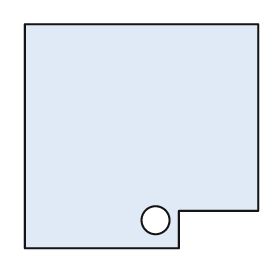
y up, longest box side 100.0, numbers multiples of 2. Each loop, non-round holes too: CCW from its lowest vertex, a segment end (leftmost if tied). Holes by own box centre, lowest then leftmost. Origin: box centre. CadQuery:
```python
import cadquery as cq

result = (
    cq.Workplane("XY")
    .moveTo(-50.0, -48.0)
    .lineTo(16.0, -48.0)
    .lineTo(16.0, -32.0)
    .lineTo(50.0, -32.0)
    .lineTo(50.0, 48.0)
    .lineTo(-50.0, 48.0)
    .close()
    .moveTo(6.0, -36.0)
    .circle(6.0)
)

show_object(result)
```